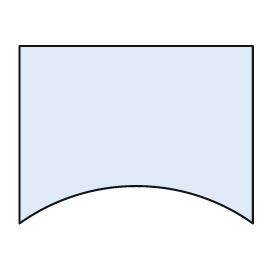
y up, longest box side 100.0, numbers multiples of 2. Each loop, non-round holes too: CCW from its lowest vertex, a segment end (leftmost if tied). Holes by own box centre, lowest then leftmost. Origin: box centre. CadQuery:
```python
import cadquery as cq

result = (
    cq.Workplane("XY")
    .moveTo(-50.0, -38.0)
    .threePointArc((0.0, -22.0), (50.0, -38.0))
    .lineTo(50.0, 38.0)
    .lineTo(-50.0, 38.0)
    .close()
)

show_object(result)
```